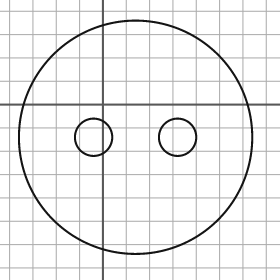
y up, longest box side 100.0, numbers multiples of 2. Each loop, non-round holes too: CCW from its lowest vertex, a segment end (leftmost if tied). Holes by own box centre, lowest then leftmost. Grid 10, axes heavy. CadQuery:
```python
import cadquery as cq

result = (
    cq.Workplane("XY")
    .moveTo(14.0, -14.0)
    .circle(50.0)
    .moveTo(-4.0, -14.0)
    .circle(8.0)
    .moveTo(32.0, -14.0)
    .circle(8.0)
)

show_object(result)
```